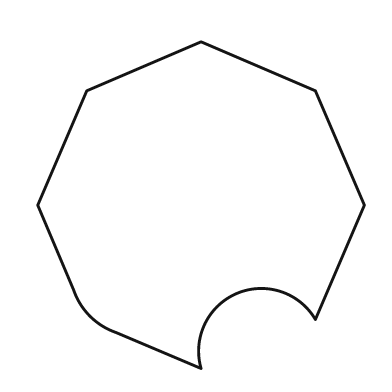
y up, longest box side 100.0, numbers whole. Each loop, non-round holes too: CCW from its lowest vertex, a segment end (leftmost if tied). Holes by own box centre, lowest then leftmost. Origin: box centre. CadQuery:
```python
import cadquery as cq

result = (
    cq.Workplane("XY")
    .moveTo(0.0, -50.0)
    .threePointArc((11.0, -27.0), (35.0, -35.0))
    .lineTo(50.0, 0.0)
    .lineTo(35.0, 35.0)
    .lineTo(0.0, 50.0)
    .lineTo(-35.0, 35.0)
    .lineTo(-50.0, 0.0)
    .lineTo(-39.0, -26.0)
    .threePointArc((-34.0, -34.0), (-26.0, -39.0))
    .close()
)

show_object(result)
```